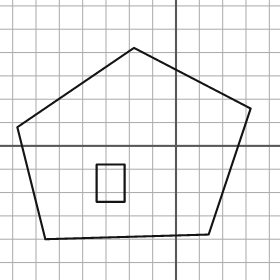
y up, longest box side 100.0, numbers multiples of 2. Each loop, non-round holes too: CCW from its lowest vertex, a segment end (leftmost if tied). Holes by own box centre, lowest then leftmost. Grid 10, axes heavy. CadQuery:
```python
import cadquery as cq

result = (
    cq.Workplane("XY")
    .moveTo(-56.0, -40.0)
    .lineTo(14.0, -38.0)
    .lineTo(32.0, 16.0)
    .lineTo(-18.0, 42.0)
    .lineTo(-68.0, 8.0)
    .close()
    .moveTo(-34.0, -24.0)
    .lineTo(-22.0, -24.0)
    .lineTo(-22.0, -8.0)
    .lineTo(-34.0, -8.0)
    .close()
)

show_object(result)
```